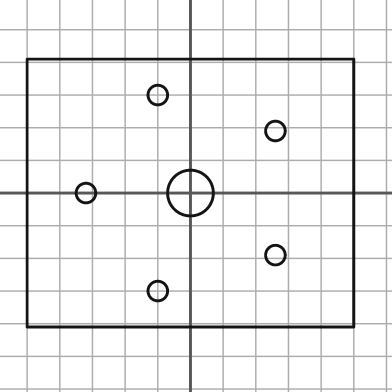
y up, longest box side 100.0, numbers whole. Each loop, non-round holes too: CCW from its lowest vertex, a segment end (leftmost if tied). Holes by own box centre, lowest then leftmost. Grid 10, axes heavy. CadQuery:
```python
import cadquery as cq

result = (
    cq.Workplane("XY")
    .moveTo(-50.0, -41.0)
    .lineTo(50.0, -41.0)
    .lineTo(50.0, 41.0)
    .lineTo(-50.0, 41.0)
    .close()
    .moveTo(-10.0, -30.0)
    .circle(3.0)
    .moveTo(26.0, -19.0)
    .circle(3.0)
    .moveTo(-32.0, 0.0)
    .circle(3.0)
    .moveTo(0.0, 0.0)
    .circle(7.0)
    .moveTo(26.0, 19.0)
    .circle(3.0)
    .moveTo(-10.0, 30.0)
    .circle(3.0)
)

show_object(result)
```